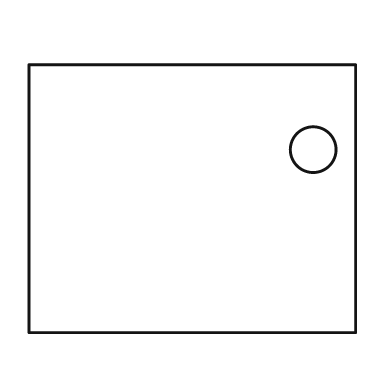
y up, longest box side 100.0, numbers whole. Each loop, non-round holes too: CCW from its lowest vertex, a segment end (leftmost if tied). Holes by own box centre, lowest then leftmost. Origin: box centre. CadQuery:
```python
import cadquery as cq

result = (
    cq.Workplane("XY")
    .moveTo(-50.0, -41.0)
    .lineTo(50.0, -41.0)
    .lineTo(50.0, 41.0)
    .lineTo(-50.0, 41.0)
    .close()
    .moveTo(37.0, 15.0)
    .circle(7.0)
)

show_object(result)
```